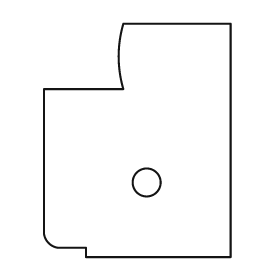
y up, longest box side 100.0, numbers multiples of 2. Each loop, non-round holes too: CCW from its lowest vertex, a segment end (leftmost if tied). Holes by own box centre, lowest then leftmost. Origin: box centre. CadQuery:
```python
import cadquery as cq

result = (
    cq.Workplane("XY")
    .moveTo(-22.0, -50.0)
    .lineTo(40.0, -50.0)
    .lineTo(40.0, 50.0)
    .lineTo(-6.0, 50.0)
    .threePointArc((-8.0, 36.0), (-6.0, 22.0))
    .lineTo(-40.0, 22.0)
    .lineTo(-40.0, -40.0)
    .threePointArc((-38.0, -44.0), (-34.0, -46.0))
    .lineTo(-22.0, -46.0)
    .close()
    .moveTo(4.0, -18.0)
    .circle(6.0)
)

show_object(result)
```